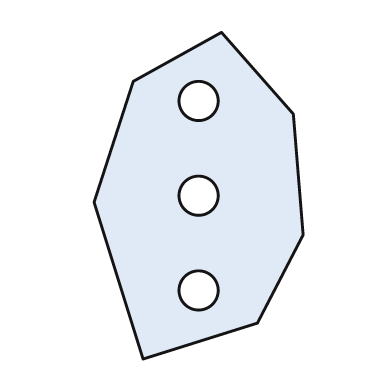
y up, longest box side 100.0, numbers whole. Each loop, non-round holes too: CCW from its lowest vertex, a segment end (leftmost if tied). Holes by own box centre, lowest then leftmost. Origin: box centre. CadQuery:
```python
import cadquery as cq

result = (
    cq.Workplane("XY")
    .moveTo(-17.0, -50.0)
    .lineTo(18.0, -39.0)
    .lineTo(32.0, -12.0)
    .lineTo(29.0, 25.0)
    .lineTo(7.0, 50.0)
    .lineTo(-20.0, 35.0)
    .lineTo(-32.0, -2.0)
    .close()
    .moveTo(0.0, -29.0)
    .circle(6.0)
    .moveTo(0.0, 0.0)
    .circle(6.0)
    .moveTo(0.0, 29.0)
    .circle(6.0)
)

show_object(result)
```